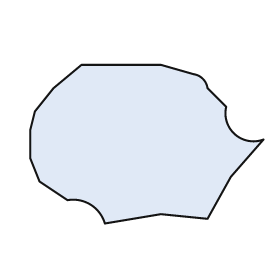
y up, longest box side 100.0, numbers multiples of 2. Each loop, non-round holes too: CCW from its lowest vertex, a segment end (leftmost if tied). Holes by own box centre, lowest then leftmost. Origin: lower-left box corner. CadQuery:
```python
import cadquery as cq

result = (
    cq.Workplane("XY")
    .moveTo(32.0, 0.0)
    .lineTo(56.0, 4.0)
    .lineTo(76.0, 2.0)
    .lineTo(86.0, 20.0)
    .lineTo(100.0, 36.0)
    .threePointArc((88.0, 38.0), (84.0, 50.0))
    .lineTo(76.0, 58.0)
    .threePointArc((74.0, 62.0), (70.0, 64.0))
    .lineTo(56.0, 68.0)
    .lineTo(22.0, 68.0)
    .lineTo(10.0, 58.0)
    .lineTo(2.0, 48.0)
    .lineTo(0.0, 40.0)
    .lineTo(0.0, 28.0)
    .lineTo(4.0, 18.0)
    .lineTo(16.0, 10.0)
    .threePointArc((26.0, 8.0), (32.0, 0.0))
    .close()
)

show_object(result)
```